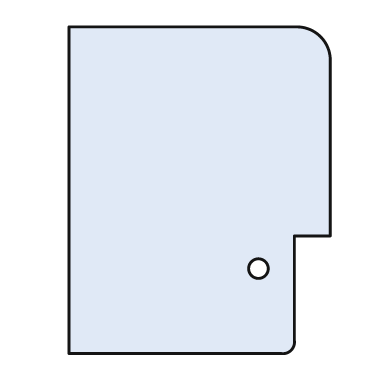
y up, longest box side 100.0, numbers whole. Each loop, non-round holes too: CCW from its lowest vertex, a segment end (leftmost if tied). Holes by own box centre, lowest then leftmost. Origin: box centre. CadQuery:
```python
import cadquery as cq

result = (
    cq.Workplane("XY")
    .moveTo(-40.0, -50.0)
    .lineTo(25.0, -50.0)
    .threePointArc((28.0, -49.0), (29.0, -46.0))
    .lineTo(29.0, -14.0)
    .lineTo(40.0, -14.0)
    .lineTo(40.0, 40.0)
    .threePointArc((37.0, 47.0), (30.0, 50.0))
    .lineTo(-40.0, 50.0)
    .close()
    .moveTo(18.0, -24.0)
    .circle(3.0)
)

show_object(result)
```